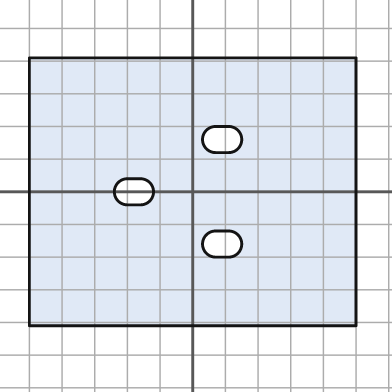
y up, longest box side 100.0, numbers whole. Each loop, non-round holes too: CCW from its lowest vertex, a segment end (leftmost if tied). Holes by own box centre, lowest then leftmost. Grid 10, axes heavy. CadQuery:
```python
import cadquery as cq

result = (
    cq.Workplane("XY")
    .moveTo(-50.0, -41.0)
    .lineTo(50.0, -41.0)
    .lineTo(50.0, 41.0)
    .lineTo(-50.0, 41.0)
    .close()
    .moveTo(7.0, -20.0)
    .lineTo(11.0, -20.0)
    .threePointArc((15.0, -16.0), (11.0, -12.0))
    .lineTo(7.0, -12.0)
    .threePointArc((3.0, -16.0), (7.0, -20.0))
    .close()
    .moveTo(-20.0, -4.0)
    .lineTo(-16.0, -4.0)
    .threePointArc((-12.0, 0.0), (-16.0, 4.0))
    .lineTo(-20.0, 4.0)
    .threePointArc((-24.0, 0.0), (-20.0, -4.0))
    .close()
    .moveTo(7.0, 12.0)
    .lineTo(11.0, 12.0)
    .threePointArc((15.0, 16.0), (11.0, 20.0))
    .lineTo(7.0, 20.0)
    .threePointArc((3.0, 16.0), (7.0, 12.0))
    .close()
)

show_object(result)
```